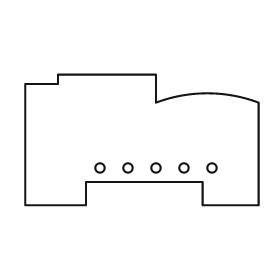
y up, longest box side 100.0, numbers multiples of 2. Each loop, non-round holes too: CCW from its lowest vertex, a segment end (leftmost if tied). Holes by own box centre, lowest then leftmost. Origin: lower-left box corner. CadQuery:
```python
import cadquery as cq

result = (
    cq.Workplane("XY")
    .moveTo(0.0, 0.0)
    .lineTo(26.0, 0.0)
    .lineTo(26.0, 10.0)
    .lineTo(76.0, 10.0)
    .lineTo(76.0, 0.0)
    .lineTo(100.0, 0.0)
    .lineTo(100.0, 44.0)
    .threePointArc((78.0, 48.0), (56.0, 44.0))
    .lineTo(56.0, 56.0)
    .lineTo(14.0, 56.0)
    .lineTo(14.0, 52.0)
    .lineTo(0.0, 52.0)
    .close()
    .moveTo(32.0, 16.0)
    .circle(2.0)
    .moveTo(44.0, 16.0)
    .circle(2.0)
    .moveTo(56.0, 16.0)
    .circle(2.0)
    .moveTo(68.0, 16.0)
    .circle(2.0)
    .moveTo(80.0, 16.0)
    .circle(2.0)
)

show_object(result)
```